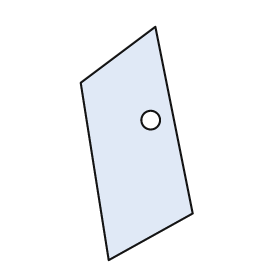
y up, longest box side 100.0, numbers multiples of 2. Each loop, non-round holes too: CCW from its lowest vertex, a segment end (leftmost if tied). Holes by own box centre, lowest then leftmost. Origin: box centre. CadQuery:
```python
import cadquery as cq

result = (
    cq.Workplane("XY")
    .moveTo(-12.0, -50.0)
    .lineTo(24.0, -30.0)
    .lineTo(8.0, 50.0)
    .lineTo(-24.0, 26.0)
    .close()
    .moveTo(6.0, 10.0)
    .circle(4.0)
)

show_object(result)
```